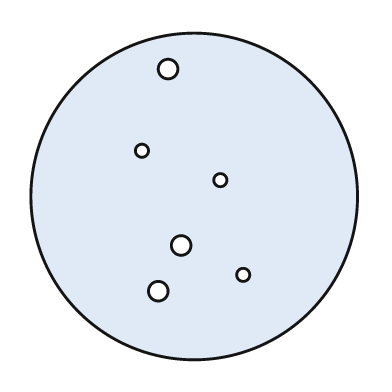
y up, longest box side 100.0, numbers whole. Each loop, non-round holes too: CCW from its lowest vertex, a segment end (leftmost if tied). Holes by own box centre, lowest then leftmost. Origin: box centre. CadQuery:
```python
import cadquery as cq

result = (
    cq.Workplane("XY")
    .moveTo(0.0, 0.0)
    .circle(50.0)
    .moveTo(-11.0, -29.0)
    .circle(3.0)
    .moveTo(15.0, -24.0)
    .circle(2.0)
    .moveTo(-4.0, -15.0)
    .circle(3.0)
    .moveTo(8.0, 5.0)
    .circle(2.0)
    .moveTo(-16.0, 14.0)
    .circle(2.0)
    .moveTo(-8.0, 39.0)
    .circle(3.0)
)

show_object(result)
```